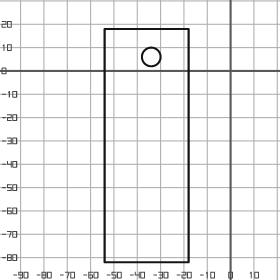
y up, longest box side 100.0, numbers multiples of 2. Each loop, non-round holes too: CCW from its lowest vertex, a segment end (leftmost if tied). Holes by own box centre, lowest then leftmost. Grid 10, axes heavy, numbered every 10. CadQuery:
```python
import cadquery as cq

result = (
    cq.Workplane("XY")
    .moveTo(-54.0, -82.0)
    .lineTo(-18.0, -82.0)
    .lineTo(-18.0, 18.0)
    .lineTo(-54.0, 18.0)
    .close()
    .moveTo(-34.0, 6.0)
    .circle(4.0)
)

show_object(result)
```